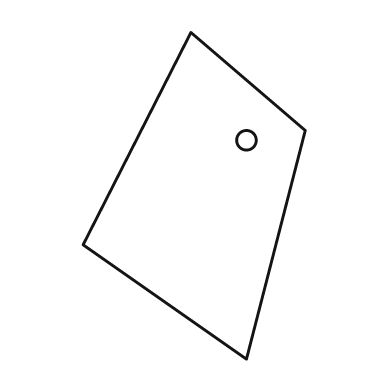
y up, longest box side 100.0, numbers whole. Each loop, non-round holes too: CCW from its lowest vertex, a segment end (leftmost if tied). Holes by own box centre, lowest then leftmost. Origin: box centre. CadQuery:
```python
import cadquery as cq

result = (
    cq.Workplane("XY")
    .moveTo(16.0, -50.0)
    .lineTo(34.0, 20.0)
    .lineTo(-1.0, 50.0)
    .lineTo(-34.0, -15.0)
    .close()
    .moveTo(16.0, 17.0)
    .circle(3.0)
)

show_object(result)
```